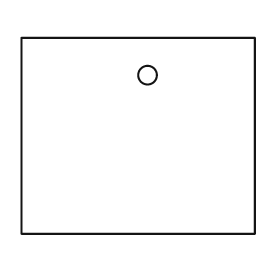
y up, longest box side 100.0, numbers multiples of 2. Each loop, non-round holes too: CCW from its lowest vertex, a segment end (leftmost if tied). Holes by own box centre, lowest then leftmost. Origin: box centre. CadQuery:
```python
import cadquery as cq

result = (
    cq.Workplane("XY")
    .moveTo(-50.0, -42.0)
    .lineTo(50.0, -42.0)
    .lineTo(50.0, 42.0)
    .lineTo(-50.0, 42.0)
    .close()
    .moveTo(4.0, 26.0)
    .circle(4.0)
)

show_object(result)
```